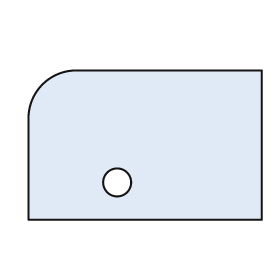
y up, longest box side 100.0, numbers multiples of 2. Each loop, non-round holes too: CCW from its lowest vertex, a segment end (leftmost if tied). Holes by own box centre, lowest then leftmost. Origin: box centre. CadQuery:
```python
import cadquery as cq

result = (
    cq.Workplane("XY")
    .moveTo(-50.0, -32.0)
    .lineTo(50.0, -32.0)
    .lineTo(50.0, 32.0)
    .lineTo(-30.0, 32.0)
    .threePointArc((-44.0, 26.0), (-50.0, 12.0))
    .close()
    .moveTo(-12.0, -16.0)
    .circle(6.0)
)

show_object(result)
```